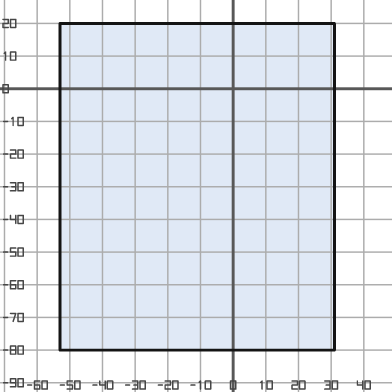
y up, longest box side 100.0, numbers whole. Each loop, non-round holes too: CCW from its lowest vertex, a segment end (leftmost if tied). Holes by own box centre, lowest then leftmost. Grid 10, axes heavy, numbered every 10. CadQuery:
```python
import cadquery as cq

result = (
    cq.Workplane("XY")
    .moveTo(-53.0, -80.0)
    .lineTo(31.0, -80.0)
    .lineTo(31.0, 20.0)
    .lineTo(-53.0, 20.0)
    .close()
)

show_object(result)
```